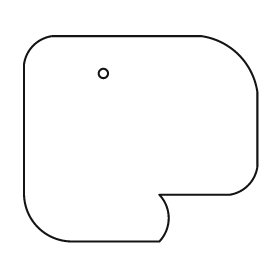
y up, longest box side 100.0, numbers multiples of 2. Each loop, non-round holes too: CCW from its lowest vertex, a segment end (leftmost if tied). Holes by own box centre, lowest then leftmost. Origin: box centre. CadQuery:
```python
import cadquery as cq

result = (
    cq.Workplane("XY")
    .moveTo(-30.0, -44.0)
    .lineTo(8.0, -44.0)
    .threePointArc((12.0, -34.0), (8.0, -24.0))
    .lineTo(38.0, -24.0)
    .threePointArc((46.0, -20.0), (50.0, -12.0))
    .lineTo(50.0, 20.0)
    .threePointArc((42.0, 36.0), (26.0, 44.0))
    .lineTo(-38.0, 44.0)
    .threePointArc((-46.0, 40.0), (-50.0, 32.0))
    .lineTo(-50.0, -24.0)
    .threePointArc((-44.0, -38.0), (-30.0, -44.0))
    .close()
    .moveTo(-16.0, 28.0)
    .circle(2.0)
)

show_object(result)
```